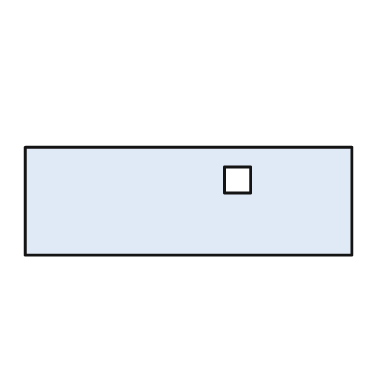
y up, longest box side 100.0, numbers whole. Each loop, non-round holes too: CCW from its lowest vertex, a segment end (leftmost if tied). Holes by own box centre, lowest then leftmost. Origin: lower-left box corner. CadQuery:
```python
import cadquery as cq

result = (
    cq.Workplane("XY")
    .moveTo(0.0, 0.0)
    .lineTo(100.0, 0.0)
    .lineTo(100.0, 33.0)
    .lineTo(0.0, 33.0)
    .close()
    .moveTo(61.0, 19.0)
    .lineTo(69.0, 19.0)
    .lineTo(69.0, 27.0)
    .lineTo(61.0, 27.0)
    .close()
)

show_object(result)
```